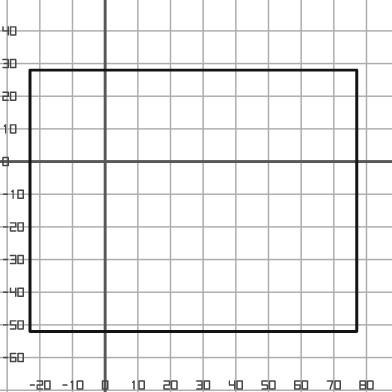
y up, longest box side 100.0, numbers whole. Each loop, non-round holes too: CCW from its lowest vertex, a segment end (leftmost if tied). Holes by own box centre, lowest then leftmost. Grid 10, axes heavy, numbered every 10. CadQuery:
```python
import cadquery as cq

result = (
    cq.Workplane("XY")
    .moveTo(-23.0, -52.0)
    .lineTo(77.0, -52.0)
    .lineTo(77.0, 28.0)
    .lineTo(-23.0, 28.0)
    .close()
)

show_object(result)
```